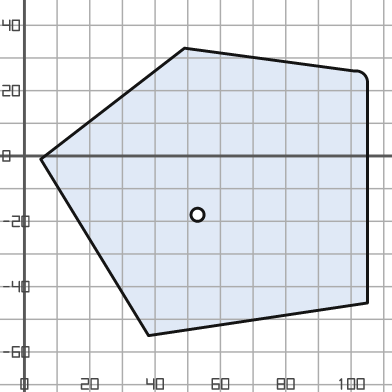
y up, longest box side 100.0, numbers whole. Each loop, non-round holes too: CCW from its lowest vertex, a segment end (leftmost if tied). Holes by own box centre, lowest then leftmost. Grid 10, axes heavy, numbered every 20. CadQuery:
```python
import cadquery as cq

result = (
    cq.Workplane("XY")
    .moveTo(38.0, -55.0)
    .lineTo(105.0, -45.0)
    .lineTo(105.0, 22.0)
    .threePointArc((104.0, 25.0), (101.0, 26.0))
    .lineTo(49.0, 33.0)
    .lineTo(5.0, -1.0)
    .close()
    .moveTo(53.0, -18.0)
    .circle(2.0)
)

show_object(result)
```